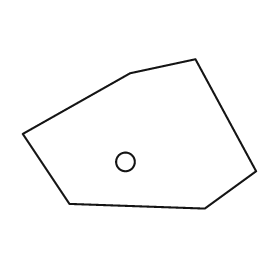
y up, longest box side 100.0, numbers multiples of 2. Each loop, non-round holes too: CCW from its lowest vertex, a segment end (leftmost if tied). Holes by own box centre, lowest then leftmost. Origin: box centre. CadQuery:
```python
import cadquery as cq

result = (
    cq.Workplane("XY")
    .moveTo(28.0, -32.0)
    .lineTo(50.0, -16.0)
    .lineTo(24.0, 32.0)
    .lineTo(-4.0, 26.0)
    .lineTo(-50.0, 0.0)
    .lineTo(-30.0, -30.0)
    .close()
    .moveTo(-6.0, -12.0)
    .circle(4.0)
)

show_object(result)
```